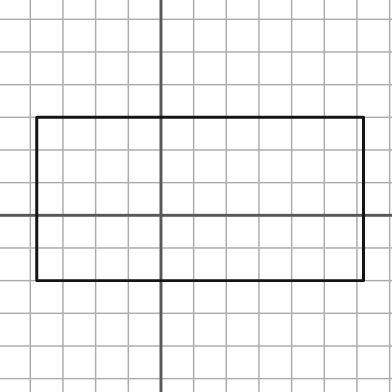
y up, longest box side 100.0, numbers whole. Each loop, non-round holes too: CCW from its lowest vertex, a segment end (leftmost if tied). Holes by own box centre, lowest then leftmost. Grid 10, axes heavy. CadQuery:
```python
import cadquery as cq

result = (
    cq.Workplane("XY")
    .moveTo(-38.0, -20.0)
    .lineTo(62.0, -20.0)
    .lineTo(62.0, 30.0)
    .lineTo(-38.0, 30.0)
    .close()
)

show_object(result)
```